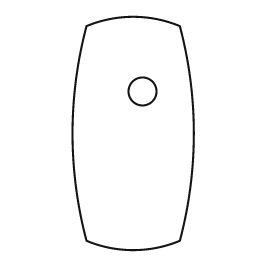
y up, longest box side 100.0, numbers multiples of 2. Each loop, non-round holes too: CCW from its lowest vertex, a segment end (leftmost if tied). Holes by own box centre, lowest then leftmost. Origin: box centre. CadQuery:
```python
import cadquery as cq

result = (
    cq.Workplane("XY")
    .moveTo(-20.0, -46.0)
    .threePointArc((0.0, -50.0), (20.0, -46.0))
    .threePointArc((26.0, 0.0), (20.0, 46.0))
    .threePointArc((0.0, 50.0), (-20.0, 46.0))
    .threePointArc((-26.0, 0.0), (-20.0, -46.0))
    .close()
    .moveTo(4.0, 18.0)
    .circle(6.0)
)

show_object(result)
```